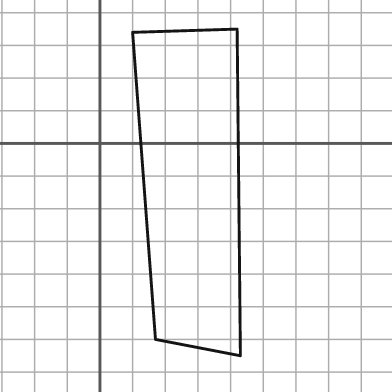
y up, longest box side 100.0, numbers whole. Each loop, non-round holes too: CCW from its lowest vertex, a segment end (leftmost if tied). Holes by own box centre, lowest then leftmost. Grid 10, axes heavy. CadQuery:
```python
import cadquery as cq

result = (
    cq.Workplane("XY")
    .moveTo(43.0, -65.0)
    .lineTo(42.0, 35.0)
    .lineTo(10.0, 34.0)
    .lineTo(17.0, -60.0)
    .close()
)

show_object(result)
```